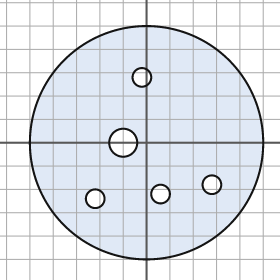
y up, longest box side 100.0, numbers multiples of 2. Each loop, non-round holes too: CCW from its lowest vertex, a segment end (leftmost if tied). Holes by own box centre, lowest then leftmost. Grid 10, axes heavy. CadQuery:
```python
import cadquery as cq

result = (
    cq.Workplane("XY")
    .moveTo(0.0, 0.0)
    .circle(50.0)
    .moveTo(-22.0, -24.0)
    .circle(4.0)
    .moveTo(6.0, -22.0)
    .circle(4.0)
    .moveTo(28.0, -18.0)
    .circle(4.0)
    .moveTo(-10.0, 0.0)
    .circle(6.0)
    .moveTo(-2.0, 28.0)
    .circle(4.0)
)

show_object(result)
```